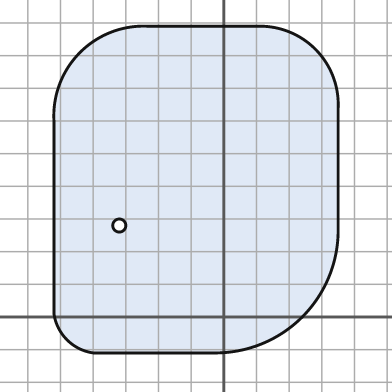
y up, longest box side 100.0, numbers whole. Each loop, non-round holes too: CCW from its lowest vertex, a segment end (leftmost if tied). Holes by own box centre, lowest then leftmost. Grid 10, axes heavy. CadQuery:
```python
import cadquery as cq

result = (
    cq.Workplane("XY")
    .moveTo(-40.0, -11.0)
    .lineTo(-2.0, -11.0)
    .threePointArc((24.0, 0.0), (35.0, 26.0))
    .lineTo(35.0, 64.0)
    .threePointArc((28.0, 82.0), (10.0, 89.0))
    .lineTo(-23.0, 89.0)
    .threePointArc((-44.0, 81.0), (-52.0, 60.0))
    .lineTo(-52.0, 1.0)
    .threePointArc((-48.0, -7.0), (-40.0, -11.0))
    .close()
    .moveTo(-32.0, 28.0)
    .circle(2.0)
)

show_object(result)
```